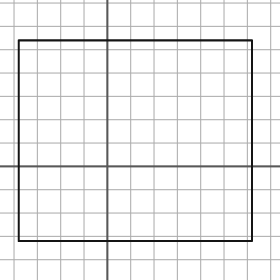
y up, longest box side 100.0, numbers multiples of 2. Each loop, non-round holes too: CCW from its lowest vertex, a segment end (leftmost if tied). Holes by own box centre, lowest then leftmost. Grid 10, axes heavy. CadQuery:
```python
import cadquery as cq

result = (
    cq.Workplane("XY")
    .moveTo(-38.0, -32.0)
    .lineTo(62.0, -32.0)
    .lineTo(62.0, 54.0)
    .lineTo(-38.0, 54.0)
    .close()
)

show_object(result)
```